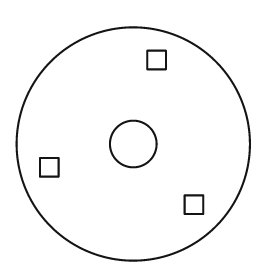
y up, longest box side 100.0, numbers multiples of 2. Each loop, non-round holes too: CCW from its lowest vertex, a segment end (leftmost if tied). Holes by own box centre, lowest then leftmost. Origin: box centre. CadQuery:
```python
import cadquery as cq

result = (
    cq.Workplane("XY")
    .moveTo(0.0, 0.0)
    .circle(50.0)
    .moveTo(22.0, -30.0)
    .lineTo(30.0, -30.0)
    .lineTo(30.0, -22.0)
    .lineTo(22.0, -22.0)
    .close()
    .moveTo(-40.0, -14.0)
    .lineTo(-32.0, -14.0)
    .lineTo(-32.0, -6.0)
    .lineTo(-40.0, -6.0)
    .close()
    .moveTo(0.0, 0.0)
    .circle(10.0)
    .moveTo(6.0, 32.0)
    .lineTo(14.0, 32.0)
    .lineTo(14.0, 40.0)
    .lineTo(6.0, 40.0)
    .close()
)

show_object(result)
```